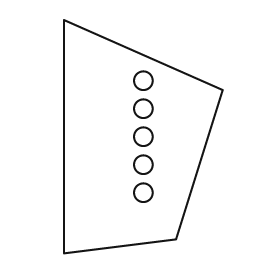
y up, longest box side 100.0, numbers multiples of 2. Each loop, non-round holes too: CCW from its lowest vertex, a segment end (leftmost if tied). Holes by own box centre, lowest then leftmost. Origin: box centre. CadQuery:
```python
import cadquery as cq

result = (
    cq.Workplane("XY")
    .moveTo(-34.0, -50.0)
    .lineTo(14.0, -44.0)
    .lineTo(34.0, 20.0)
    .lineTo(-34.0, 50.0)
    .close()
    .moveTo(0.0, -24.0)
    .circle(4.0)
    .moveTo(0.0, -12.0)
    .circle(4.0)
    .moveTo(0.0, 0.0)
    .circle(4.0)
    .moveTo(0.0, 12.0)
    .circle(4.0)
    .moveTo(0.0, 24.0)
    .circle(4.0)
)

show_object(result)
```